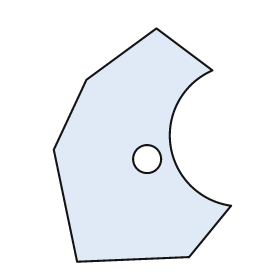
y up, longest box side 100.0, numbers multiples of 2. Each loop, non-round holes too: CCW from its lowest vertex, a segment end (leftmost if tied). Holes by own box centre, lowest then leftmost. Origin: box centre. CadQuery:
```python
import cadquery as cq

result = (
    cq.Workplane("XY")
    .moveTo(-28.0, -50.0)
    .lineTo(20.0, -48.0)
    .lineTo(38.0, -26.0)
    .threePointArc((12.0, 0.0), (30.0, 32.0))
    .lineTo(6.0, 50.0)
    .lineTo(-24.0, 28.0)
    .lineTo(-38.0, -2.0)
    .close()
    .moveTo(2.0, -6.0)
    .circle(6.0)
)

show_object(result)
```